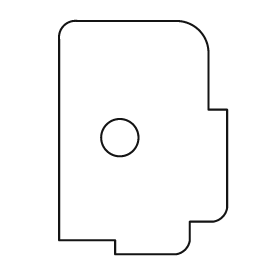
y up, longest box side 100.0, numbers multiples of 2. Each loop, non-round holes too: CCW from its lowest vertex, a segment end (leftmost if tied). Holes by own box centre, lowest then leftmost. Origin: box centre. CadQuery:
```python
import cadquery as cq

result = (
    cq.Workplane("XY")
    .moveTo(-12.0, -50.0)
    .lineTo(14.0, -50.0)
    .threePointArc((18.0, -48.0), (20.0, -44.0))
    .lineTo(20.0, -36.0)
    .lineTo(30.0, -36.0)
    .threePointArc((34.0, -34.0), (36.0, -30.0))
    .lineTo(36.0, 12.0)
    .lineTo(28.0, 12.0)
    .lineTo(28.0, 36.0)
    .threePointArc((24.0, 46.0), (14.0, 50.0))
    .lineTo(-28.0, 50.0)
    .threePointArc((-34.0, 48.0), (-36.0, 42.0))
    .lineTo(-36.0, -44.0)
    .lineTo(-12.0, -44.0)
    .close()
    .moveTo(-10.0, 0.0)
    .circle(8.0)
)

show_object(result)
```